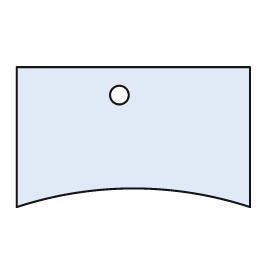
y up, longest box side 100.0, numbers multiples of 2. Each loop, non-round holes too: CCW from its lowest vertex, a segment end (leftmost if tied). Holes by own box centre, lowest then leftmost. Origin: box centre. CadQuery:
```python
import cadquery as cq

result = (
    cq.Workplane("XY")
    .moveTo(-50.0, -30.0)
    .threePointArc((0.0, -22.0), (50.0, -30.0))
    .lineTo(50.0, 30.0)
    .lineTo(-50.0, 30.0)
    .close()
    .moveTo(-6.0, 18.0)
    .circle(4.0)
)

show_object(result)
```